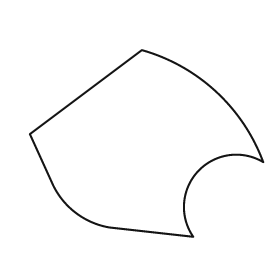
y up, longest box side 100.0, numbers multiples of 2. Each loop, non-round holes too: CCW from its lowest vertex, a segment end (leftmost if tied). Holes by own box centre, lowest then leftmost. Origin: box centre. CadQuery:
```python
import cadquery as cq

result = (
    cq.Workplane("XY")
    .moveTo(20.0, -40.0)
    .threePointArc((22.0, -12.0), (50.0, -8.0))
    .threePointArc((30.0, 22.0), (-2.0, 40.0))
    .lineTo(-50.0, 4.0)
    .lineTo(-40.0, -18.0)
    .threePointArc((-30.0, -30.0), (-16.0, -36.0))
    .close()
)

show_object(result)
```